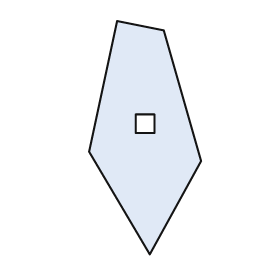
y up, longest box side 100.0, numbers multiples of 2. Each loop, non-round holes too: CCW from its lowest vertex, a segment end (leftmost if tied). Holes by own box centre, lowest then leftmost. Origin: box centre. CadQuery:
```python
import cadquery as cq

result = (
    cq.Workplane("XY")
    .moveTo(2.0, -50.0)
    .lineTo(24.0, -10.0)
    .lineTo(8.0, 46.0)
    .lineTo(-12.0, 50.0)
    .lineTo(-24.0, -6.0)
    .close()
    .moveTo(-4.0, 2.0)
    .lineTo(4.0, 2.0)
    .lineTo(4.0, 10.0)
    .lineTo(-4.0, 10.0)
    .close()
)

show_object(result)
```